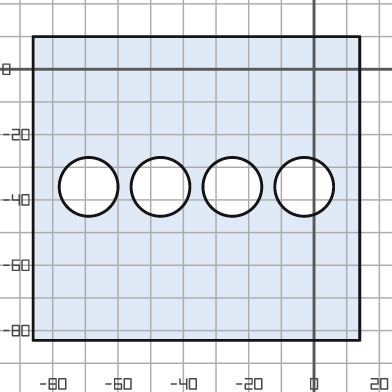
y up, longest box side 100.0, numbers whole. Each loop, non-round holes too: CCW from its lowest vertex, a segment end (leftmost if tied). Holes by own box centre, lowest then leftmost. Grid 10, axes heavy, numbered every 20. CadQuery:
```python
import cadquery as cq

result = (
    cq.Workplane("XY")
    .moveTo(-86.0, -83.0)
    .lineTo(14.0, -83.0)
    .lineTo(14.0, 10.0)
    .lineTo(-86.0, 10.0)
    .close()
    .moveTo(-69.0, -36.0)
    .circle(9.0)
    .moveTo(-47.0, -36.0)
    .circle(9.0)
    .moveTo(-25.0, -36.0)
    .circle(9.0)
    .moveTo(-3.0, -36.0)
    .circle(9.0)
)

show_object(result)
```